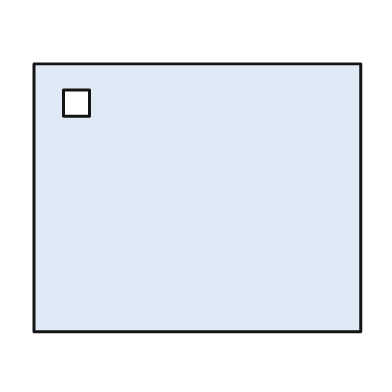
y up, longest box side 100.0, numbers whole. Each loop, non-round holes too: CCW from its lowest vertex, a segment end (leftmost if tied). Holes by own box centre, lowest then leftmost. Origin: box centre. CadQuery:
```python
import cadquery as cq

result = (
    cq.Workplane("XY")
    .moveTo(-50.0, -41.0)
    .lineTo(50.0, -41.0)
    .lineTo(50.0, 41.0)
    .lineTo(-50.0, 41.0)
    .close()
    .moveTo(-41.0, 25.0)
    .lineTo(-33.0, 25.0)
    .lineTo(-33.0, 33.0)
    .lineTo(-41.0, 33.0)
    .close()
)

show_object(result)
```